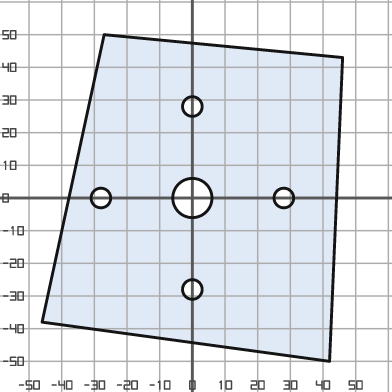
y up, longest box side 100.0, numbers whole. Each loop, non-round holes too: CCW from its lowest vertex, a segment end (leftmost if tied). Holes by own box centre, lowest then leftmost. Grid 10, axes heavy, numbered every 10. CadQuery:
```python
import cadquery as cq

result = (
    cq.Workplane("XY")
    .moveTo(42.0, -50.0)
    .lineTo(46.0, 43.0)
    .lineTo(-27.0, 50.0)
    .lineTo(-46.0, -38.0)
    .close()
    .moveTo(0.0, -28.0)
    .circle(3.0)
    .moveTo(-28.0, 0.0)
    .circle(3.0)
    .moveTo(0.0, 0.0)
    .circle(6.0)
    .moveTo(28.0, 0.0)
    .circle(3.0)
    .moveTo(0.0, 28.0)
    .circle(3.0)
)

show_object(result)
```